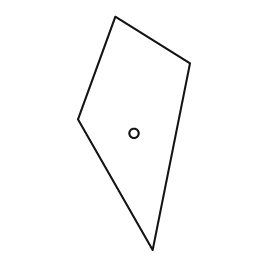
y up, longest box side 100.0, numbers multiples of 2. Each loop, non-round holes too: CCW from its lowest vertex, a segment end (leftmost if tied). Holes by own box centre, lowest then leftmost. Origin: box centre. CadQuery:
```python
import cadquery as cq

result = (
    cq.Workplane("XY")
    .moveTo(8.0, -50.0)
    .lineTo(24.0, 30.0)
    .lineTo(-8.0, 50.0)
    .lineTo(-24.0, 6.0)
    .close()
    .moveTo(0.0, 0.0)
    .circle(2.0)
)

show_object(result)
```